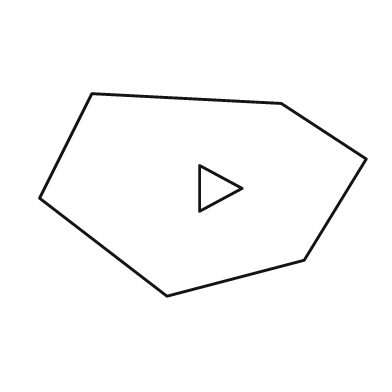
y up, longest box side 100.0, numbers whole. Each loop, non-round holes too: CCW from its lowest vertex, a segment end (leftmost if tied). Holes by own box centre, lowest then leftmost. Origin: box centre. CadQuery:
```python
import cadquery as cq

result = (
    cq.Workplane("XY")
    .moveTo(-11.0, -31.0)
    .lineTo(31.0, -20.0)
    .lineTo(50.0, 11.0)
    .lineTo(24.0, 28.0)
    .lineTo(-34.0, 31.0)
    .lineTo(-50.0, -1.0)
    .close()
    .moveTo(-1.0, -5.0)
    .lineTo(12.0, 2.0)
    .lineTo(-1.0, 9.0)
    .close()
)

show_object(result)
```